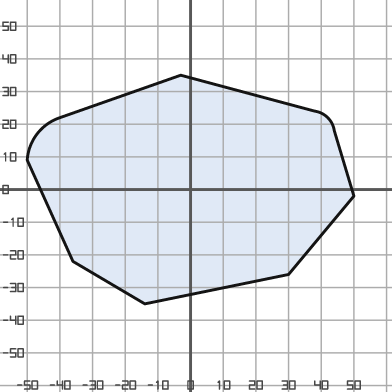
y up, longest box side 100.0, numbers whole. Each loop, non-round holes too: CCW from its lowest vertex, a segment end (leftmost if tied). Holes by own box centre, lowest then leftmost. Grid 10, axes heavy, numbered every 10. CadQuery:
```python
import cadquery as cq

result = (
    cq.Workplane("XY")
    .moveTo(-14.0, -35.0)
    .lineTo(30.0, -26.0)
    .lineTo(50.0, -2.0)
    .lineTo(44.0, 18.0)
    .threePointArc((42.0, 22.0), (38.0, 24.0))
    .lineTo(-3.0, 35.0)
    .lineTo(-40.0, 22.0)
    .threePointArc((-47.0, 17.0), (-50.0, 9.0))
    .lineTo(-36.0, -22.0)
    .close()
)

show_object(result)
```